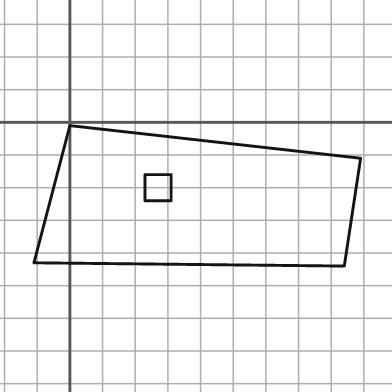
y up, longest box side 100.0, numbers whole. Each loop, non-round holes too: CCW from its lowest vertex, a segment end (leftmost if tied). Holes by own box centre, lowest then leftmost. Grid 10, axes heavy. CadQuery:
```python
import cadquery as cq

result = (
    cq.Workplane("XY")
    .moveTo(84.0, -44.0)
    .lineTo(89.0, -11.0)
    .lineTo(0.0, -1.0)
    .lineTo(-11.0, -43.0)
    .close()
    .moveTo(23.0, -24.0)
    .lineTo(31.0, -24.0)
    .lineTo(31.0, -16.0)
    .lineTo(23.0, -16.0)
    .close()
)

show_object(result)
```